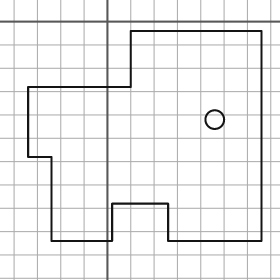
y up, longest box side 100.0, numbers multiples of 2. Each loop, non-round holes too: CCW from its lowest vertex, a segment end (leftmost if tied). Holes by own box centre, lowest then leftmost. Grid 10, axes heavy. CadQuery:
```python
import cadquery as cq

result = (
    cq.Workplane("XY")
    .moveTo(-24.0, -94.0)
    .lineTo(2.0, -94.0)
    .lineTo(2.0, -78.0)
    .lineTo(26.0, -78.0)
    .lineTo(26.0, -94.0)
    .lineTo(66.0, -94.0)
    .lineTo(66.0, -4.0)
    .lineTo(10.0, -4.0)
    .lineTo(10.0, -28.0)
    .lineTo(-34.0, -28.0)
    .lineTo(-34.0, -58.0)
    .lineTo(-24.0, -58.0)
    .close()
    .moveTo(46.0, -42.0)
    .circle(4.0)
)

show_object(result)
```